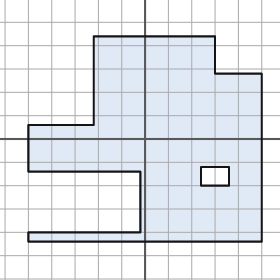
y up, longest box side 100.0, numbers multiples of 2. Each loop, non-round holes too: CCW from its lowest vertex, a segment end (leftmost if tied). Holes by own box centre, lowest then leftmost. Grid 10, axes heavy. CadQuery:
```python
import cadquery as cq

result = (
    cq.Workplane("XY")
    .moveTo(-50.0, -44.0)
    .lineTo(50.0, -44.0)
    .lineTo(50.0, 28.0)
    .lineTo(30.0, 28.0)
    .lineTo(30.0, 44.0)
    .lineTo(-22.0, 44.0)
    .lineTo(-22.0, 6.0)
    .lineTo(-50.0, 6.0)
    .lineTo(-50.0, -14.0)
    .lineTo(-2.0, -14.0)
    .lineTo(-2.0, -40.0)
    .lineTo(-50.0, -40.0)
    .close()
    .moveTo(24.0, -20.0)
    .lineTo(36.0, -20.0)
    .lineTo(36.0, -12.0)
    .lineTo(24.0, -12.0)
    .close()
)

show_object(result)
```